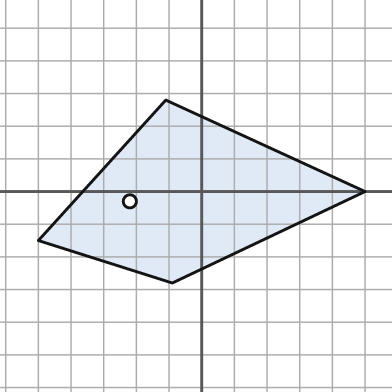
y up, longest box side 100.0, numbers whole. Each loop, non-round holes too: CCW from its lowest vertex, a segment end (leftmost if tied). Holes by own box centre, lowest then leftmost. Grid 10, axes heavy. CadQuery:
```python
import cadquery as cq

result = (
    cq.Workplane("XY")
    .moveTo(-9.0, -28.0)
    .lineTo(50.0, 0.0)
    .lineTo(-11.0, 28.0)
    .lineTo(-50.0, -15.0)
    .close()
    .moveTo(-22.0, -3.0)
    .circle(2.0)
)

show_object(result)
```